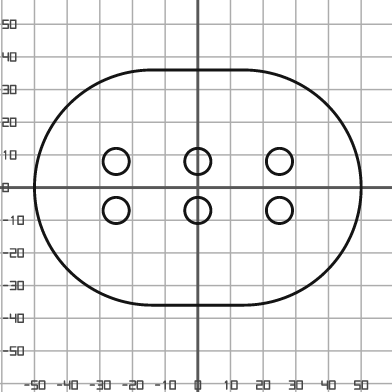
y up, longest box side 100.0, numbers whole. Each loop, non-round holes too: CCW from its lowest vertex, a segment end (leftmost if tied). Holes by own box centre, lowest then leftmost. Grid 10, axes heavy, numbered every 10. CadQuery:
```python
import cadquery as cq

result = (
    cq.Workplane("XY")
    .moveTo(-14.0, -36.0)
    .lineTo(14.0, -36.0)
    .threePointArc((50.0, 0.0), (14.0, 36.0))
    .lineTo(-14.0, 36.0)
    .threePointArc((-50.0, 0.0), (-14.0, -36.0))
    .close()
    .moveTo(-25.0, -7.0)
    .circle(4.0)
    .moveTo(0.0, -7.0)
    .circle(4.0)
    .moveTo(25.0, -7.0)
    .circle(4.0)
    .moveTo(-25.0, 8.0)
    .circle(4.0)
    .moveTo(0.0, 8.0)
    .circle(4.0)
    .moveTo(25.0, 8.0)
    .circle(4.0)
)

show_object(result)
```